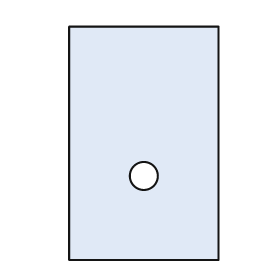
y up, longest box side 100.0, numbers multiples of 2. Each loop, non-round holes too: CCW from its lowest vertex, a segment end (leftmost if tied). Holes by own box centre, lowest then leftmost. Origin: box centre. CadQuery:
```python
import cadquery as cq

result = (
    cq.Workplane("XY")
    .moveTo(-32.0, -50.0)
    .lineTo(32.0, -50.0)
    .lineTo(32.0, 50.0)
    .lineTo(-32.0, 50.0)
    .close()
    .moveTo(0.0, -14.0)
    .circle(6.0)
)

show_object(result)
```